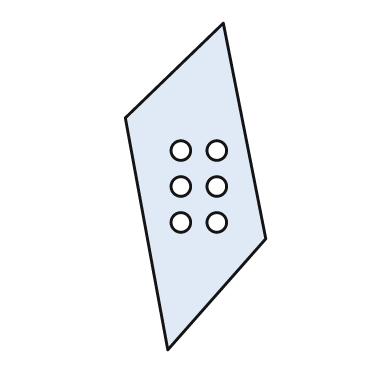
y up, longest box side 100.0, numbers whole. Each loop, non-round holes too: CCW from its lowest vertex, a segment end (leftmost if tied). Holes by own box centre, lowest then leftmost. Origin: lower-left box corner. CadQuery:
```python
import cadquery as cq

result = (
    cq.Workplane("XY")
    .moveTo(13.0, 0.0)
    .lineTo(43.0, 34.0)
    .lineTo(30.0, 100.0)
    .lineTo(0.0, 71.0)
    .close()
    .moveTo(17.0, 39.0)
    .circle(3.0)
    .moveTo(28.0, 39.0)
    .circle(3.0)
    .moveTo(17.0, 50.0)
    .circle(3.0)
    .moveTo(28.0, 50.0)
    .circle(3.0)
    .moveTo(17.0, 61.0)
    .circle(3.0)
    .moveTo(28.0, 61.0)
    .circle(3.0)
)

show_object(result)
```